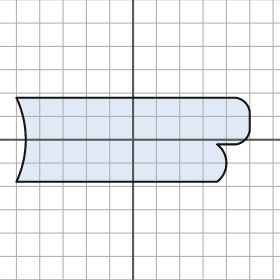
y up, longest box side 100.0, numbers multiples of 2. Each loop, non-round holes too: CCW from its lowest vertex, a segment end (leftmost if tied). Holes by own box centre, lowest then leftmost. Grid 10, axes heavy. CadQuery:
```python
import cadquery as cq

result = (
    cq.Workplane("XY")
    .moveTo(-50.0, -18.0)
    .lineTo(36.0, -18.0)
    .threePointArc((40.0, -10.0), (36.0, -2.0))
    .lineTo(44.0, -2.0)
    .threePointArc((48.0, 0.0), (50.0, 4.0))
    .lineTo(50.0, 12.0)
    .threePointArc((48.0, 16.0), (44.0, 18.0))
    .lineTo(-50.0, 18.0)
    .threePointArc((-46.0, 0.0), (-50.0, -18.0))
    .close()
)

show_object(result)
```